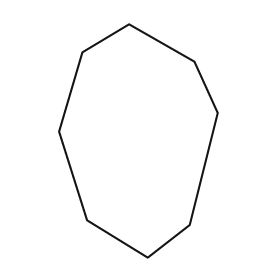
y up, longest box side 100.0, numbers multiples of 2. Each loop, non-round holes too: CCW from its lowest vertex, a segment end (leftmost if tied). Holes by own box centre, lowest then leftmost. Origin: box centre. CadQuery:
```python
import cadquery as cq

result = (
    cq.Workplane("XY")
    .moveTo(4.0, -50.0)
    .lineTo(22.0, -36.0)
    .lineTo(34.0, 12.0)
    .lineTo(24.0, 34.0)
    .lineTo(-4.0, 50.0)
    .lineTo(-24.0, 38.0)
    .lineTo(-34.0, 4.0)
    .lineTo(-22.0, -34.0)
    .close()
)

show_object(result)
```